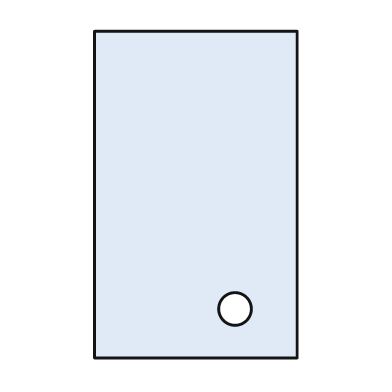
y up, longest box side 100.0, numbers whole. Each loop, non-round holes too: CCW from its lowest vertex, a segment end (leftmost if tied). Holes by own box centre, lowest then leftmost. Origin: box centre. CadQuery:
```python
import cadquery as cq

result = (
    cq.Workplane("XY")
    .moveTo(-31.0, -50.0)
    .lineTo(31.0, -50.0)
    .lineTo(31.0, 50.0)
    .lineTo(-31.0, 50.0)
    .close()
    .moveTo(12.0, -35.0)
    .circle(5.0)
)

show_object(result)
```